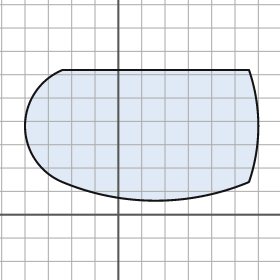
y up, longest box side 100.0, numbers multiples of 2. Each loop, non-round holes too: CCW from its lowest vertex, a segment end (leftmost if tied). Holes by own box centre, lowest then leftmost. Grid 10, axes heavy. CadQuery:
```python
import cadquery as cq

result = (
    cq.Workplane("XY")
    .moveTo(-24.0, 14.0)
    .threePointArc((16.0, 6.0), (56.0, 14.0))
    .threePointArc((60.0, 38.0), (56.0, 62.0))
    .lineTo(-24.0, 62.0)
    .threePointArc((-40.0, 38.0), (-24.0, 14.0))
    .close()
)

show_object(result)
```